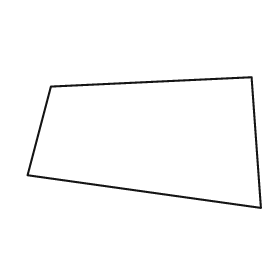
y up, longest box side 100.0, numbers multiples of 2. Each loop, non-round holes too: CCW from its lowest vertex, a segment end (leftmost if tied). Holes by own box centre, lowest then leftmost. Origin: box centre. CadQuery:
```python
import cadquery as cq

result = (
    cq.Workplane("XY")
    .moveTo(50.0, -28.0)
    .lineTo(46.0, 28.0)
    .lineTo(-40.0, 24.0)
    .lineTo(-50.0, -14.0)
    .close()
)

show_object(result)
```